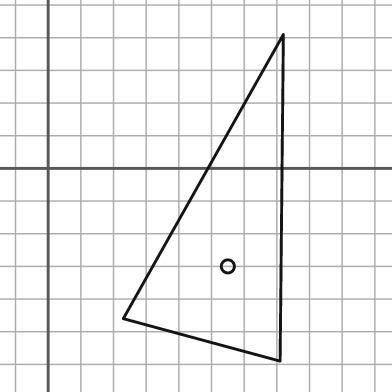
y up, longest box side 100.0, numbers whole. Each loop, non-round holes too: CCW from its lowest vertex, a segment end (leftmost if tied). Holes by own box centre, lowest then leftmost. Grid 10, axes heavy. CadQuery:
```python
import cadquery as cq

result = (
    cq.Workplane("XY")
    .moveTo(71.0, -59.0)
    .lineTo(72.0, 41.0)
    .lineTo(23.0, -46.0)
    .close()
    .moveTo(55.0, -30.0)
    .circle(2.0)
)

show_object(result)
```